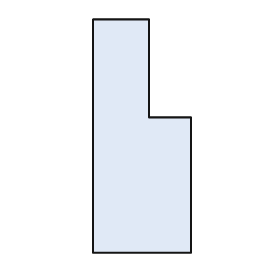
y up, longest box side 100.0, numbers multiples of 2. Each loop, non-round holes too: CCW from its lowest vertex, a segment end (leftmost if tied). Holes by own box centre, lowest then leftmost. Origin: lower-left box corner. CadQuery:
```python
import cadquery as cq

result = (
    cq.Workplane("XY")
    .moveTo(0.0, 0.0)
    .lineTo(42.0, 0.0)
    .lineTo(42.0, 58.0)
    .lineTo(24.0, 58.0)
    .lineTo(24.0, 100.0)
    .lineTo(0.0, 100.0)
    .close()
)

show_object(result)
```